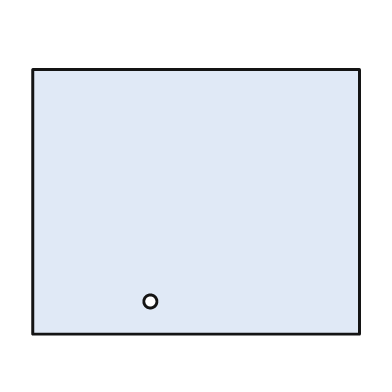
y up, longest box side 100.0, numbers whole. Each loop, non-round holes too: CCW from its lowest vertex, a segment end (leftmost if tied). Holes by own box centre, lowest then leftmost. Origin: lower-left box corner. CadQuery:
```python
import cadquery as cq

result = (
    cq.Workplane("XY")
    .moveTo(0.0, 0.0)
    .lineTo(100.0, 0.0)
    .lineTo(100.0, 81.0)
    .lineTo(0.0, 81.0)
    .close()
    .moveTo(36.0, 10.0)
    .circle(2.0)
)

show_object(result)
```